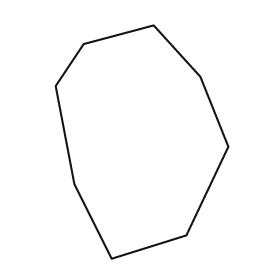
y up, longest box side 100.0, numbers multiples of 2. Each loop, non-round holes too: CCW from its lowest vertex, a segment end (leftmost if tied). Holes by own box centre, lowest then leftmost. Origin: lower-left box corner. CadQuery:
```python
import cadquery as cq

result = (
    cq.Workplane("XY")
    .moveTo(24.0, 0.0)
    .lineTo(56.0, 10.0)
    .lineTo(74.0, 48.0)
    .lineTo(62.0, 78.0)
    .lineTo(42.0, 100.0)
    .lineTo(12.0, 92.0)
    .lineTo(0.0, 74.0)
    .lineTo(8.0, 32.0)
    .close()
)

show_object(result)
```